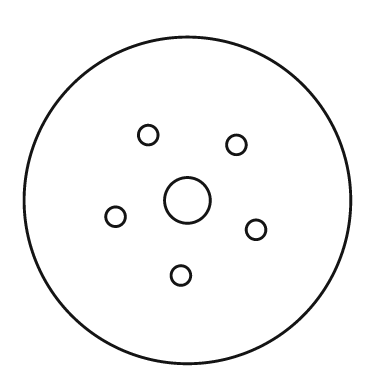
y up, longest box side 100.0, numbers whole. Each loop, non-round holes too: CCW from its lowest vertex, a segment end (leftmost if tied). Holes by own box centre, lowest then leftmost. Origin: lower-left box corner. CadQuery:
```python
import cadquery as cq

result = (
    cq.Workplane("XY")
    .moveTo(50.0, 50.0)
    .circle(50.0)
    .moveTo(48.0, 27.0)
    .circle(3.0)
    .moveTo(71.0, 41.0)
    .circle(3.0)
    .moveTo(28.0, 45.0)
    .circle(3.0)
    .moveTo(50.0, 50.0)
    .circle(7.0)
    .moveTo(65.0, 67.0)
    .circle(3.0)
    .moveTo(38.0, 70.0)
    .circle(3.0)
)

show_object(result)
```